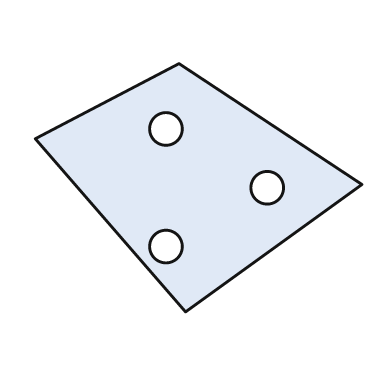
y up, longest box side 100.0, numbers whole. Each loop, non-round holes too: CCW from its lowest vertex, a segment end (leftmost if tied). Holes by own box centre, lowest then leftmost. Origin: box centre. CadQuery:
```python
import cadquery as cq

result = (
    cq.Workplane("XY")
    .moveTo(-4.0, -38.0)
    .lineTo(50.0, 1.0)
    .lineTo(-6.0, 38.0)
    .lineTo(-50.0, 15.0)
    .close()
    .moveTo(-10.0, -18.0)
    .circle(5.0)
    .moveTo(21.0, 0.0)
    .circle(5.0)
    .moveTo(-10.0, 18.0)
    .circle(5.0)
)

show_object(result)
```